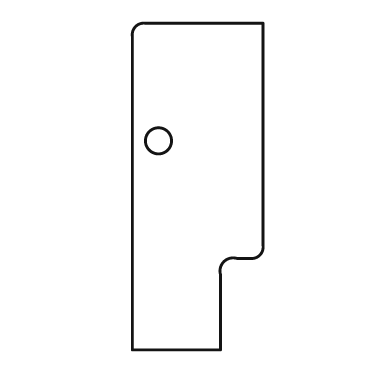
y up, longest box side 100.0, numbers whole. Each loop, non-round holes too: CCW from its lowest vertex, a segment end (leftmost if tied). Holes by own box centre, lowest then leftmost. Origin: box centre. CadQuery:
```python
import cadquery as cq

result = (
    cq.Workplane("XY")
    .moveTo(-20.0, -50.0)
    .lineTo(7.0, -50.0)
    .lineTo(7.0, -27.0)
    .threePointArc((8.0, -23.0), (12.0, -22.0))
    .lineTo(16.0, -22.0)
    .threePointArc((19.0, -21.0), (20.0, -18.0))
    .lineTo(20.0, 50.0)
    .lineTo(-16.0, 50.0)
    .threePointArc((-19.0, 49.0), (-20.0, 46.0))
    .close()
    .moveTo(-12.0, 14.0)
    .circle(4.0)
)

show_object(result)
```